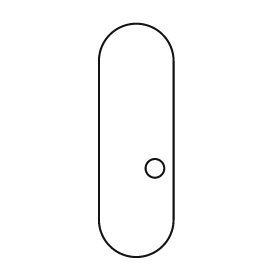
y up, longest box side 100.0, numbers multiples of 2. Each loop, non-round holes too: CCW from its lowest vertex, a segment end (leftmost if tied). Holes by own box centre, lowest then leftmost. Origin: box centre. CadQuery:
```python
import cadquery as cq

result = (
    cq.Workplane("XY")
    .moveTo(-16.0, -34.0)
    .threePointArc((0.0, -50.0), (16.0, -34.0))
    .lineTo(16.0, 34.0)
    .threePointArc((0.0, 50.0), (-16.0, 34.0))
    .close()
    .moveTo(8.0, -12.0)
    .circle(4.0)
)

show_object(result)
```